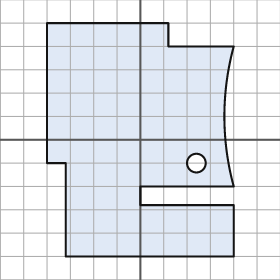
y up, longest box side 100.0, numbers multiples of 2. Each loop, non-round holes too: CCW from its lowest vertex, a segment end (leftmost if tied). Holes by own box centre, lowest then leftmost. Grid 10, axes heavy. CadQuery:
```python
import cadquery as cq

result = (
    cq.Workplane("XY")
    .moveTo(-32.0, -50.0)
    .lineTo(40.0, -50.0)
    .lineTo(40.0, -28.0)
    .lineTo(0.0, -28.0)
    .lineTo(0.0, -20.0)
    .lineTo(40.0, -20.0)
    .threePointArc((36.0, 10.0), (40.0, 40.0))
    .lineTo(12.0, 40.0)
    .lineTo(12.0, 50.0)
    .lineTo(-40.0, 50.0)
    .lineTo(-40.0, -10.0)
    .lineTo(-32.0, -10.0)
    .close()
    .moveTo(24.0, -10.0)
    .circle(4.0)
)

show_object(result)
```